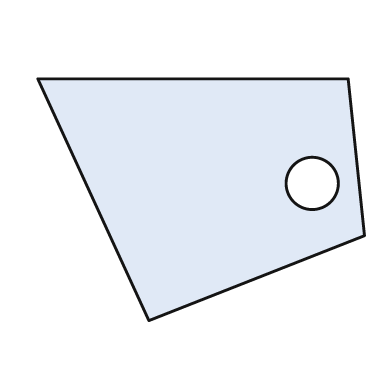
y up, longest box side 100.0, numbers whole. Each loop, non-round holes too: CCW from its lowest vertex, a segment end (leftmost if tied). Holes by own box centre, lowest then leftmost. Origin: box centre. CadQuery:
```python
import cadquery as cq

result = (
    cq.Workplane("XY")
    .moveTo(-16.0, -37.0)
    .lineTo(50.0, -11.0)
    .lineTo(45.0, 37.0)
    .lineTo(-50.0, 37.0)
    .close()
    .moveTo(34.0, 5.0)
    .circle(8.0)
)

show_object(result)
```